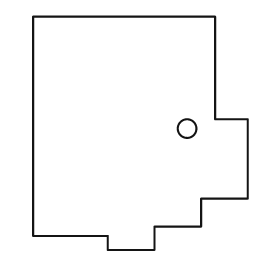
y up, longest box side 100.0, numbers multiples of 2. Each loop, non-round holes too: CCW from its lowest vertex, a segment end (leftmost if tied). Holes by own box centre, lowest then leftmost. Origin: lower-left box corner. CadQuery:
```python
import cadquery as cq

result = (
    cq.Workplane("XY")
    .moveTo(32.0, 0.0)
    .lineTo(52.0, 0.0)
    .lineTo(52.0, 10.0)
    .lineTo(72.0, 10.0)
    .lineTo(72.0, 22.0)
    .lineTo(92.0, 22.0)
    .lineTo(92.0, 56.0)
    .lineTo(78.0, 56.0)
    .lineTo(78.0, 100.0)
    .lineTo(0.0, 100.0)
    .lineTo(0.0, 6.0)
    .lineTo(32.0, 6.0)
    .close()
    .moveTo(66.0, 52.0)
    .circle(4.0)
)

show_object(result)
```